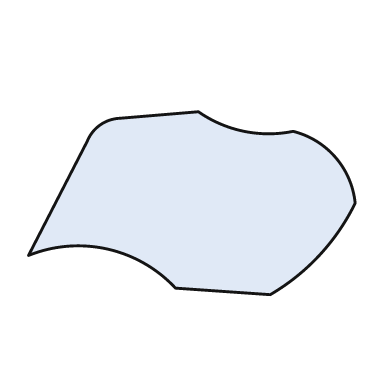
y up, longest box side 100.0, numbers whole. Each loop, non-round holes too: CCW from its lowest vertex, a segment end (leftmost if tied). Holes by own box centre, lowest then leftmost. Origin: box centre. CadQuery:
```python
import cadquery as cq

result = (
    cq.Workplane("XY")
    .moveTo(24.0, -28.0)
    .threePointArc((39.0, -16.0), (50.0, 0.0))
    .threePointArc((44.0, 14.0), (31.0, 22.0))
    .threePointArc((16.0, 22.0), (2.0, 28.0))
    .lineTo(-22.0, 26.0)
    .threePointArc((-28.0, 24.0), (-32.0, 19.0))
    .lineTo(-50.0, -16.0)
    .threePointArc((-26.0, -14.0), (-5.0, -26.0))
    .close()
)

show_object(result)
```